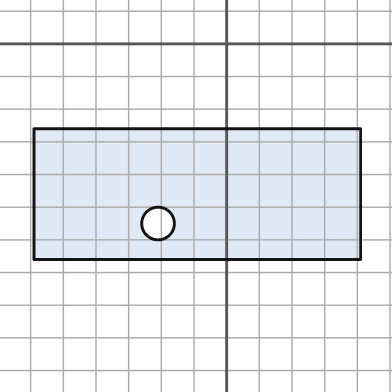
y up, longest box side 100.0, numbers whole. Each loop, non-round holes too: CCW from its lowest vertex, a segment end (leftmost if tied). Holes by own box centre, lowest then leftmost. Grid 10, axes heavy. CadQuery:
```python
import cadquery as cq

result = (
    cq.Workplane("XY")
    .moveTo(-59.0, -66.0)
    .lineTo(41.0, -66.0)
    .lineTo(41.0, -26.0)
    .lineTo(-59.0, -26.0)
    .close()
    .moveTo(-21.0, -55.0)
    .circle(5.0)
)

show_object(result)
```